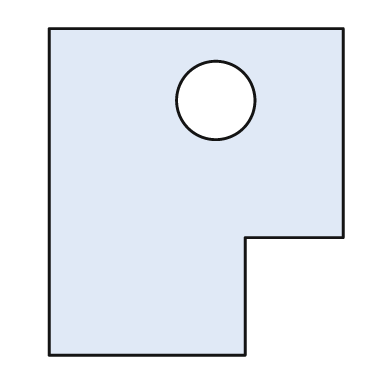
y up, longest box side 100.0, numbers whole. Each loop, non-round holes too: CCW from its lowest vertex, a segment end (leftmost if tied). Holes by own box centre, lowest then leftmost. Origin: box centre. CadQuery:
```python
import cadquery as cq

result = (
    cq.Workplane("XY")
    .moveTo(-45.0, -50.0)
    .lineTo(15.0, -50.0)
    .lineTo(15.0, -14.0)
    .lineTo(45.0, -14.0)
    .lineTo(45.0, 50.0)
    .lineTo(-45.0, 50.0)
    .close()
    .moveTo(6.0, 28.0)
    .circle(12.0)
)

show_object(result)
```